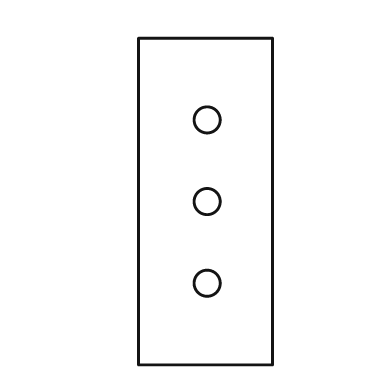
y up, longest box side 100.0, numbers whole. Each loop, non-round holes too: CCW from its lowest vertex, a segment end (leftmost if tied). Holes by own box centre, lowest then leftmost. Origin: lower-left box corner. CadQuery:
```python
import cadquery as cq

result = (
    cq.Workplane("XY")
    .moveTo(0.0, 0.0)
    .lineTo(41.0, 0.0)
    .lineTo(41.0, 100.0)
    .lineTo(0.0, 100.0)
    .close()
    .moveTo(21.0, 25.0)
    .circle(4.0)
    .moveTo(21.0, 50.0)
    .circle(4.0)
    .moveTo(21.0, 75.0)
    .circle(4.0)
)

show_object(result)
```